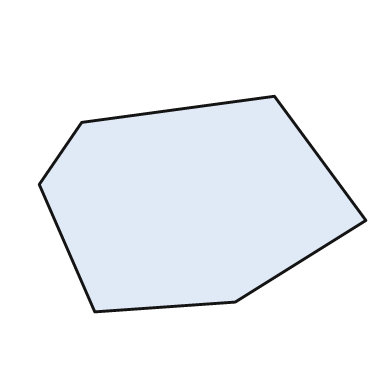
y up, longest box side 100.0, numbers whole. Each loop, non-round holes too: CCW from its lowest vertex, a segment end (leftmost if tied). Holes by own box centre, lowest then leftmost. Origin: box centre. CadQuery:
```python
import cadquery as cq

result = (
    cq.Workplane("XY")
    .moveTo(-33.0, -33.0)
    .lineTo(10.0, -30.0)
    .lineTo(50.0, -5.0)
    .lineTo(22.0, 33.0)
    .lineTo(-37.0, 25.0)
    .lineTo(-50.0, 6.0)
    .close()
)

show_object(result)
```